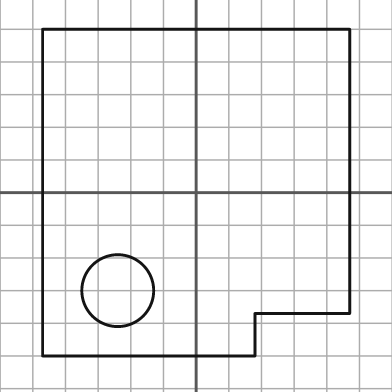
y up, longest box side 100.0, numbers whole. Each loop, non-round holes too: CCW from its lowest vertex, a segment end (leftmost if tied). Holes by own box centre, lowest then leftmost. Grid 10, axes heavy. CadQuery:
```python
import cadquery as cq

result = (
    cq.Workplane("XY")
    .moveTo(-47.0, -50.0)
    .lineTo(18.0, -50.0)
    .lineTo(18.0, -37.0)
    .lineTo(47.0, -37.0)
    .lineTo(47.0, 50.0)
    .lineTo(-47.0, 50.0)
    .close()
    .moveTo(-24.0, -30.0)
    .circle(11.0)
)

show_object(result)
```